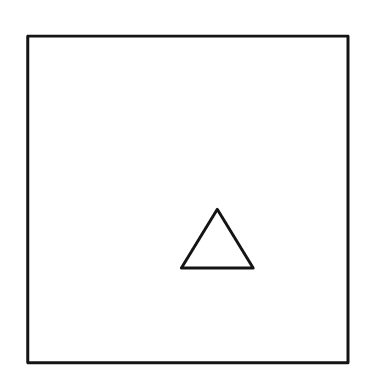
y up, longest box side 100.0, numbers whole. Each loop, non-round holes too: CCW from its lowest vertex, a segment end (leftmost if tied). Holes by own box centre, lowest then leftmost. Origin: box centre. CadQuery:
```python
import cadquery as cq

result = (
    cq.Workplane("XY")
    .moveTo(-49.0, -50.0)
    .lineTo(49.0, -50.0)
    .lineTo(49.0, 50.0)
    .lineTo(-49.0, 50.0)
    .close()
    .moveTo(-2.0, -21.0)
    .lineTo(20.0, -21.0)
    .lineTo(9.0, -3.0)
    .close()
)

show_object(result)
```